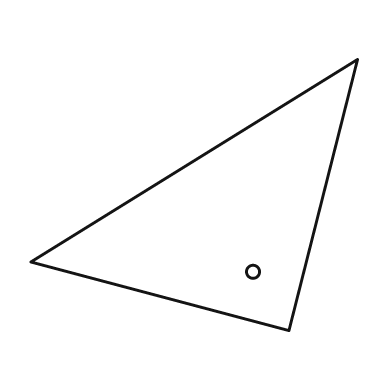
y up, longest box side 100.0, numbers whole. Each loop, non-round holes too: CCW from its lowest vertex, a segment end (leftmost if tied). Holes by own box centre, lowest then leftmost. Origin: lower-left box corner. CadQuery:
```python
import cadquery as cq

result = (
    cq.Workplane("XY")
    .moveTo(79.0, 0.0)
    .lineTo(100.0, 83.0)
    .lineTo(0.0, 21.0)
    .close()
    .moveTo(68.0, 18.0)
    .circle(2.0)
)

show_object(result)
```